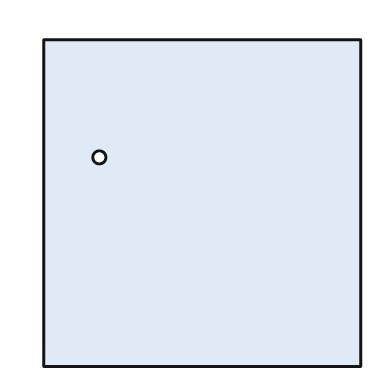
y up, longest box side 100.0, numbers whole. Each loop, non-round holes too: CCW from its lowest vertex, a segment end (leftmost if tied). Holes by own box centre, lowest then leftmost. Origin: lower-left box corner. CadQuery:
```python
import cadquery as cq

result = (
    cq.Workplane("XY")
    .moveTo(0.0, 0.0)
    .lineTo(97.0, 0.0)
    .lineTo(97.0, 100.0)
    .lineTo(0.0, 100.0)
    .close()
    .moveTo(17.0, 64.0)
    .circle(2.0)
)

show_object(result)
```